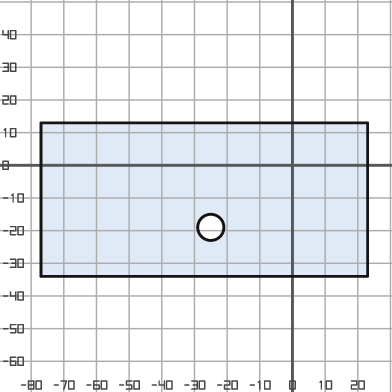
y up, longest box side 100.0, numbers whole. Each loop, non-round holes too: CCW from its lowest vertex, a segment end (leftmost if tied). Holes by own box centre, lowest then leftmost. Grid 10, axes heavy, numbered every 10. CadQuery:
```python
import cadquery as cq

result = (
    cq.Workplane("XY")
    .moveTo(-77.0, -34.0)
    .lineTo(23.0, -34.0)
    .lineTo(23.0, 13.0)
    .lineTo(-77.0, 13.0)
    .close()
    .moveTo(-25.0, -19.0)
    .circle(4.0)
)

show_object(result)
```